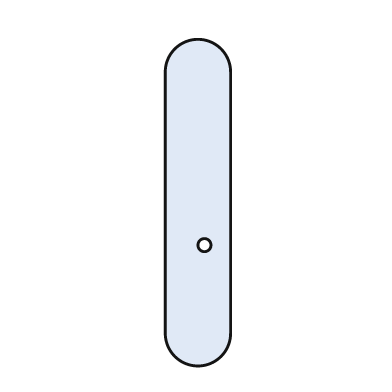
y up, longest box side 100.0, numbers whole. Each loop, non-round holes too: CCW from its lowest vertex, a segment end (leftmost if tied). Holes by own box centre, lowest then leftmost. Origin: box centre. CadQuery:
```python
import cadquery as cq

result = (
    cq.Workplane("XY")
    .moveTo(-10.0, -40.0)
    .threePointArc((0.0, -50.0), (10.0, -40.0))
    .lineTo(10.0, 40.0)
    .threePointArc((0.0, 50.0), (-10.0, 40.0))
    .close()
    .moveTo(2.0, -13.0)
    .circle(2.0)
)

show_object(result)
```